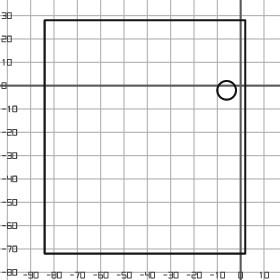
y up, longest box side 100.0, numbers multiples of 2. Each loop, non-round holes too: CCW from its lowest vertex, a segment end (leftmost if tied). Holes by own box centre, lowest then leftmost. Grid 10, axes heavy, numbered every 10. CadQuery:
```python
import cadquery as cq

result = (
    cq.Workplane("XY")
    .moveTo(-84.0, -72.0)
    .lineTo(2.0, -72.0)
    .lineTo(2.0, 28.0)
    .lineTo(-84.0, 28.0)
    .close()
    .moveTo(-6.0, -2.0)
    .circle(4.0)
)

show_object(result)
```